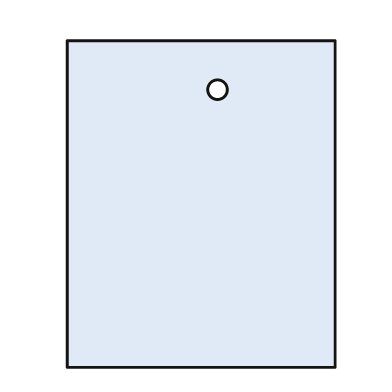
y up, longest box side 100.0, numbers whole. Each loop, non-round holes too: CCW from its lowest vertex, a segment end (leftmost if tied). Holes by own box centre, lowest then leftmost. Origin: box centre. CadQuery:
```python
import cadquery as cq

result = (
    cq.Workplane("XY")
    .moveTo(-41.0, -50.0)
    .lineTo(41.0, -50.0)
    .lineTo(41.0, 50.0)
    .lineTo(-41.0, 50.0)
    .close()
    .moveTo(5.0, 35.0)
    .circle(3.0)
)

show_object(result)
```